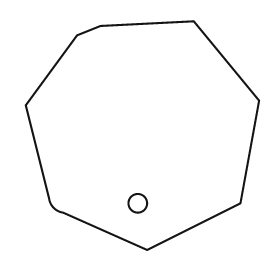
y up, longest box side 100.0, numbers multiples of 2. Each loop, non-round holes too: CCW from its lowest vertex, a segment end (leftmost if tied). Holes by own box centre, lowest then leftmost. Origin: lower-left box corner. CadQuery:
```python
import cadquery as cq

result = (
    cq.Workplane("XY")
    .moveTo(52.0, 0.0)
    .lineTo(92.0, 20.0)
    .lineTo(100.0, 64.0)
    .lineTo(72.0, 98.0)
    .lineTo(32.0, 96.0)
    .lineTo(22.0, 92.0)
    .lineTo(0.0, 62.0)
    .lineTo(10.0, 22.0)
    .threePointArc((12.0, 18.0), (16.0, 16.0))
    .close()
    .moveTo(48.0, 20.0)
    .circle(4.0)
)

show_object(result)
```